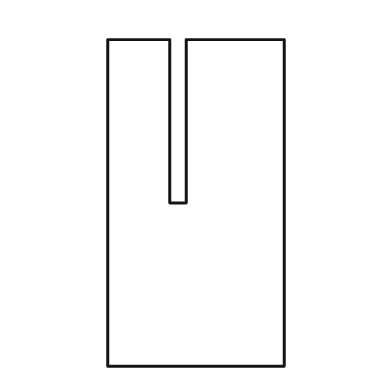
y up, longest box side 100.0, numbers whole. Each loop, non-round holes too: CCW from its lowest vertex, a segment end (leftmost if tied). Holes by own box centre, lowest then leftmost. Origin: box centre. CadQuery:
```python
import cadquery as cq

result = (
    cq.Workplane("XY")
    .moveTo(-27.0, -50.0)
    .lineTo(27.0, -50.0)
    .lineTo(27.0, 50.0)
    .lineTo(-3.0, 50.0)
    .lineTo(-3.0, 0.0)
    .lineTo(-8.0, 0.0)
    .lineTo(-8.0, 50.0)
    .lineTo(-27.0, 50.0)
    .close()
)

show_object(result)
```